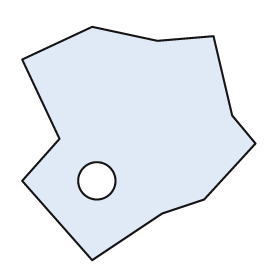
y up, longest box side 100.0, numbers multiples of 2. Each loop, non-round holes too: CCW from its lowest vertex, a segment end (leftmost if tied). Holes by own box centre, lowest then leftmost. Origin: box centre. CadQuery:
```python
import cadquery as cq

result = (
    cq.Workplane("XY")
    .moveTo(-20.0, -50.0)
    .lineTo(10.0, -30.0)
    .lineTo(28.0, -24.0)
    .lineTo(50.0, 0.0)
    .lineTo(40.0, 12.0)
    .lineTo(32.0, 46.0)
    .lineTo(8.0, 44.0)
    .lineTo(-20.0, 50.0)
    .lineTo(-50.0, 36.0)
    .lineTo(-34.0, 2.0)
    .lineTo(-50.0, -16.0)
    .close()
    .moveTo(-18.0, -16.0)
    .circle(8.0)
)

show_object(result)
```